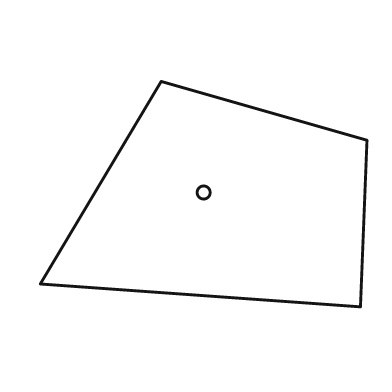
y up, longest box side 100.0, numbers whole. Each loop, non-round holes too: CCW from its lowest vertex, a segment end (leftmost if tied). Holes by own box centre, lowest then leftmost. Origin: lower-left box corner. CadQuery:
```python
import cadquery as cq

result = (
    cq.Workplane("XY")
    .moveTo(98.0, 0.0)
    .lineTo(100.0, 51.0)
    .lineTo(37.0, 69.0)
    .lineTo(0.0, 7.0)
    .close()
    .moveTo(50.0, 35.0)
    .circle(2.0)
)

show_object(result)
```